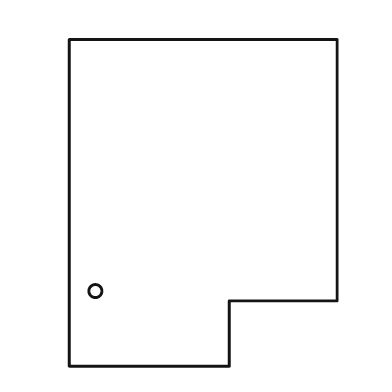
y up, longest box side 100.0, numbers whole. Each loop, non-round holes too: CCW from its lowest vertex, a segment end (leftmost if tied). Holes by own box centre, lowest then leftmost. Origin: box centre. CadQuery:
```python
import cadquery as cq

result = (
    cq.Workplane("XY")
    .moveTo(-41.0, -50.0)
    .lineTo(8.0, -50.0)
    .lineTo(8.0, -30.0)
    .lineTo(41.0, -30.0)
    .lineTo(41.0, 50.0)
    .lineTo(-41.0, 50.0)
    .close()
    .moveTo(-33.0, -27.0)
    .circle(2.0)
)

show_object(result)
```